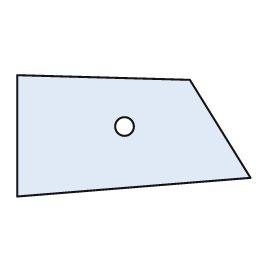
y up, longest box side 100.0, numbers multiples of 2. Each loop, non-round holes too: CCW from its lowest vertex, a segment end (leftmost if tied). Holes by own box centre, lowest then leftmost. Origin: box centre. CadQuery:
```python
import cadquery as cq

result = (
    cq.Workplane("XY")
    .moveTo(-50.0, -26.0)
    .lineTo(50.0, -18.0)
    .lineTo(24.0, 24.0)
    .lineTo(-50.0, 26.0)
    .close()
    .moveTo(-4.0, 4.0)
    .circle(4.0)
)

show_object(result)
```